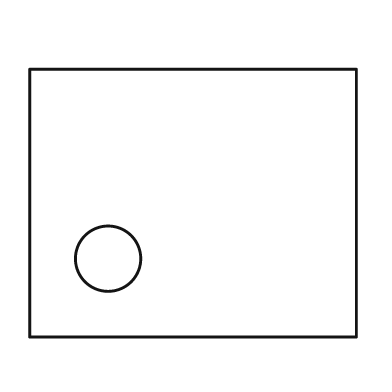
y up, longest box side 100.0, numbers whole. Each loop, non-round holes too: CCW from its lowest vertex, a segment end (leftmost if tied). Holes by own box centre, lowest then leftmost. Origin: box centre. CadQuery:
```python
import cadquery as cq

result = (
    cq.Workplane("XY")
    .moveTo(-50.0, -41.0)
    .lineTo(50.0, -41.0)
    .lineTo(50.0, 41.0)
    .lineTo(-50.0, 41.0)
    .close()
    .moveTo(-26.0, -17.0)
    .circle(10.0)
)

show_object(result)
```